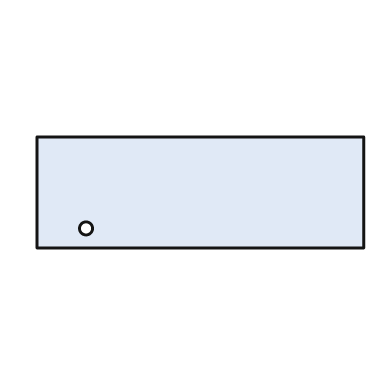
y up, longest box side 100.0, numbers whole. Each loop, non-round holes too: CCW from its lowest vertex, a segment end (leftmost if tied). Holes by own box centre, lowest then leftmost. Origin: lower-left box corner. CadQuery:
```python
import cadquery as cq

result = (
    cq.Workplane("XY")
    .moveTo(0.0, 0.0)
    .lineTo(100.0, 0.0)
    .lineTo(100.0, 34.0)
    .lineTo(0.0, 34.0)
    .close()
    .moveTo(15.0, 6.0)
    .circle(2.0)
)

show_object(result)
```